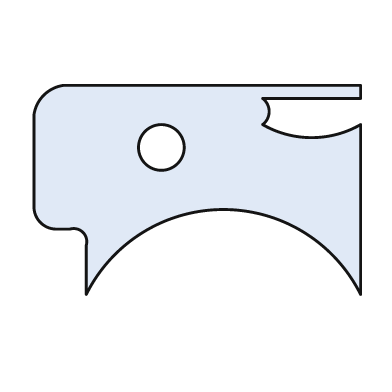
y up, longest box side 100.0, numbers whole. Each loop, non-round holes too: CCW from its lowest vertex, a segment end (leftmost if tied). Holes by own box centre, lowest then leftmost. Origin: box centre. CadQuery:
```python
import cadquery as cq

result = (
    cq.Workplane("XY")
    .moveTo(-34.0, -32.0)
    .threePointArc((8.0, -6.0), (50.0, -32.0))
    .lineTo(50.0, 20.0)
    .threePointArc((35.0, 16.0), (20.0, 20.0))
    .threePointArc((22.0, 24.0), (20.0, 28.0))
    .lineTo(50.0, 28.0)
    .lineTo(50.0, 32.0)
    .lineTo(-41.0, 32.0)
    .threePointArc((-47.0, 29.0), (-50.0, 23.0))
    .lineTo(-50.0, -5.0)
    .threePointArc((-48.0, -10.0), (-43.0, -12.0))
    .lineTo(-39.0, -12.0)
    .threePointArc((-35.0, -13.0), (-34.0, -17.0))
    .close()
    .moveTo(-11.0, 13.0)
    .circle(7.0)
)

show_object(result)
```